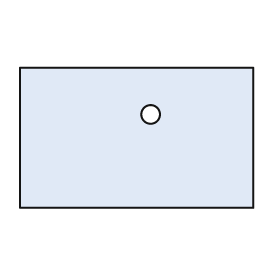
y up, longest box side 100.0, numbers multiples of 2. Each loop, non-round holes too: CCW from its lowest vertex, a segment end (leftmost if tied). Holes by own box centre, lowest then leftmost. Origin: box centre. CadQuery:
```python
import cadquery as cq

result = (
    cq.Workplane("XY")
    .moveTo(-50.0, -30.0)
    .lineTo(50.0, -30.0)
    .lineTo(50.0, 30.0)
    .lineTo(-50.0, 30.0)
    .close()
    .moveTo(6.0, 10.0)
    .circle(4.0)
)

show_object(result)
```